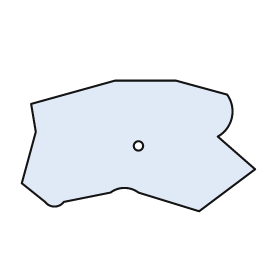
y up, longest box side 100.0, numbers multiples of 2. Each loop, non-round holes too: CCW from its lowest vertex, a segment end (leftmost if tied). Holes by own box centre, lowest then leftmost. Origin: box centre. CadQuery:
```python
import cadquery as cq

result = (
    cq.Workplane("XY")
    .moveTo(26.0, -28.0)
    .lineTo(50.0, -10.0)
    .lineTo(34.0, 4.0)
    .threePointArc((40.0, 12.0), (38.0, 22.0))
    .lineTo(16.0, 28.0)
    .lineTo(-10.0, 28.0)
    .lineTo(-46.0, 18.0)
    .lineTo(-44.0, 6.0)
    .lineTo(-50.0, -16.0)
    .lineTo(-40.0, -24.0)
    .threePointArc((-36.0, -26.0), (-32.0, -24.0))
    .lineTo(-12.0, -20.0)
    .threePointArc((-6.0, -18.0), (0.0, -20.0))
    .close()
    .moveTo(0.0, 0.0)
    .circle(2.0)
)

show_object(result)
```